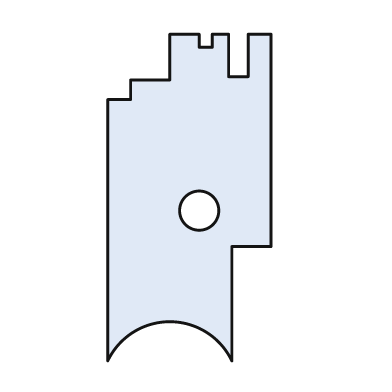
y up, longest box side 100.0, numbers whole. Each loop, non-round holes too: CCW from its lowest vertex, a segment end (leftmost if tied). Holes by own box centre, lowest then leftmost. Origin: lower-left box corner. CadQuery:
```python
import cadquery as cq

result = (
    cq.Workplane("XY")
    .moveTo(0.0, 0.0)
    .threePointArc((19.0, 12.0), (38.0, 0.0))
    .lineTo(38.0, 35.0)
    .lineTo(50.0, 35.0)
    .lineTo(50.0, 100.0)
    .lineTo(43.0, 100.0)
    .lineTo(43.0, 87.0)
    .lineTo(37.0, 87.0)
    .lineTo(37.0, 100.0)
    .lineTo(32.0, 100.0)
    .lineTo(32.0, 96.0)
    .lineTo(28.0, 96.0)
    .lineTo(28.0, 100.0)
    .lineTo(19.0, 100.0)
    .lineTo(19.0, 86.0)
    .lineTo(7.0, 86.0)
    .lineTo(7.0, 80.0)
    .lineTo(0.0, 80.0)
    .close()
    .moveTo(28.0, 46.0)
    .circle(6.0)
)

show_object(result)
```